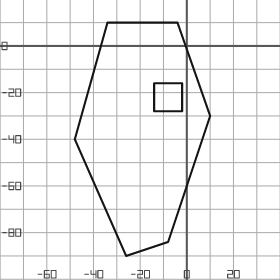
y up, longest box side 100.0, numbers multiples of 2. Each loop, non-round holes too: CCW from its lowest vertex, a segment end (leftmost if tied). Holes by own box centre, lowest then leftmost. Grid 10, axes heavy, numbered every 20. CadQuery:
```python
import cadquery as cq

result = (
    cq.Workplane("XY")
    .moveTo(-26.0, -90.0)
    .lineTo(-8.0, -84.0)
    .lineTo(10.0, -30.0)
    .lineTo(-4.0, 10.0)
    .lineTo(-34.0, 10.0)
    .lineTo(-48.0, -40.0)
    .close()
    .moveTo(-14.0, -28.0)
    .lineTo(-2.0, -28.0)
    .lineTo(-2.0, -16.0)
    .lineTo(-14.0, -16.0)
    .close()
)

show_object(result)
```